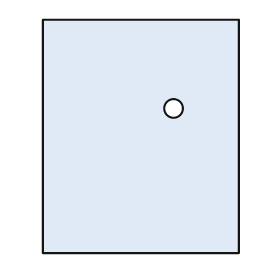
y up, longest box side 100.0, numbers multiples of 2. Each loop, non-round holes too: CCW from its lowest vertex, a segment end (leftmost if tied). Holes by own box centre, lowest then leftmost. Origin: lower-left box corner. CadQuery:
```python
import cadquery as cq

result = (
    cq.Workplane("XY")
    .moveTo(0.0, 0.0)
    .lineTo(84.0, 0.0)
    .lineTo(84.0, 100.0)
    .lineTo(0.0, 100.0)
    .close()
    .moveTo(56.0, 62.0)
    .circle(4.0)
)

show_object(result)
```